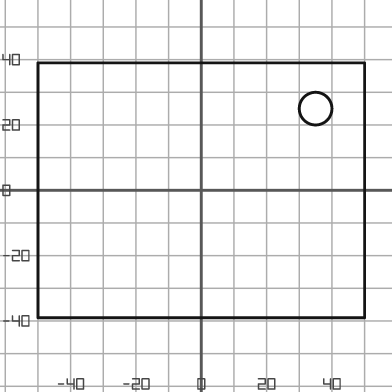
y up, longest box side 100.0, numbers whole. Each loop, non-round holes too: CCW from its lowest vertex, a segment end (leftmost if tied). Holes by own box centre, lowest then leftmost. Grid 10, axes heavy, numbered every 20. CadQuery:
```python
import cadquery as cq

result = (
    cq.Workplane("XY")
    .moveTo(-50.0, -39.0)
    .lineTo(50.0, -39.0)
    .lineTo(50.0, 39.0)
    .lineTo(-50.0, 39.0)
    .close()
    .moveTo(35.0, 25.0)
    .circle(5.0)
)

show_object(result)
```